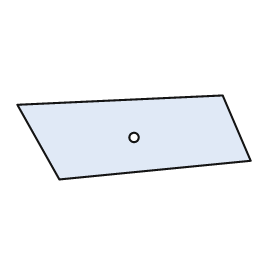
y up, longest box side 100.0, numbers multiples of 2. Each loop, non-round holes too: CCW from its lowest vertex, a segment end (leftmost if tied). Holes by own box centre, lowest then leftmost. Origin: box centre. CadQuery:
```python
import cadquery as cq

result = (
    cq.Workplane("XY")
    .moveTo(-32.0, -18.0)
    .lineTo(50.0, -10.0)
    .lineTo(38.0, 18.0)
    .lineTo(-50.0, 14.0)
    .close()
    .moveTo(0.0, 0.0)
    .circle(2.0)
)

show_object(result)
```